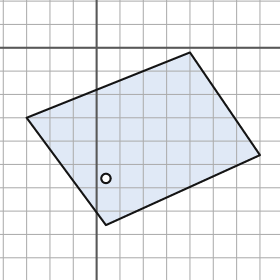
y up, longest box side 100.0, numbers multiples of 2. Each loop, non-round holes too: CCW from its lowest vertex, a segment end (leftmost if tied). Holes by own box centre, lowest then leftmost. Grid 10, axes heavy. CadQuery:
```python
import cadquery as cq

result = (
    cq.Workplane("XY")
    .moveTo(4.0, -76.0)
    .lineTo(70.0, -46.0)
    .lineTo(40.0, -2.0)
    .lineTo(-30.0, -30.0)
    .close()
    .moveTo(4.0, -56.0)
    .circle(2.0)
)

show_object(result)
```